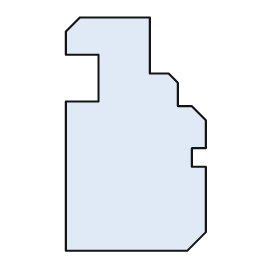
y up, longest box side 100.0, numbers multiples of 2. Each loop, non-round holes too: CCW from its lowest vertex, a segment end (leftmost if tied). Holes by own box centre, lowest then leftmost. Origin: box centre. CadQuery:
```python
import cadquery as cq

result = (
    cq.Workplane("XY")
    .moveTo(-30.0, -50.0)
    .lineTo(22.0, -50.0)
    .lineTo(30.0, -42.0)
    .lineTo(30.0, -14.0)
    .lineTo(24.0, -14.0)
    .lineTo(24.0, -6.0)
    .lineTo(30.0, -6.0)
    .lineTo(30.0, 6.0)
    .lineTo(24.0, 12.0)
    .lineTo(18.0, 12.0)
    .lineTo(18.0, 22.0)
    .lineTo(14.0, 26.0)
    .lineTo(6.0, 26.0)
    .lineTo(6.0, 50.0)
    .lineTo(-24.0, 50.0)
    .lineTo(-30.0, 44.0)
    .lineTo(-30.0, 34.0)
    .lineTo(-16.0, 34.0)
    .lineTo(-16.0, 14.0)
    .lineTo(-30.0, 14.0)
    .close()
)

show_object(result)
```